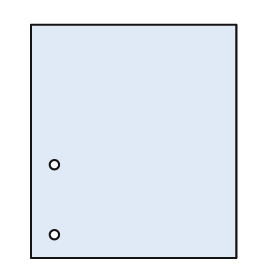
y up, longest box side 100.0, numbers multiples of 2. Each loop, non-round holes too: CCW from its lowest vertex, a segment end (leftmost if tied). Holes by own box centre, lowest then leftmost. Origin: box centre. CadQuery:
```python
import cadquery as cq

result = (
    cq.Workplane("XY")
    .moveTo(-44.0, -50.0)
    .lineTo(44.0, -50.0)
    .lineTo(44.0, 50.0)
    .lineTo(-44.0, 50.0)
    .close()
    .moveTo(-34.0, -40.0)
    .circle(2.0)
    .moveTo(-34.0, -10.0)
    .circle(2.0)
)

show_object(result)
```